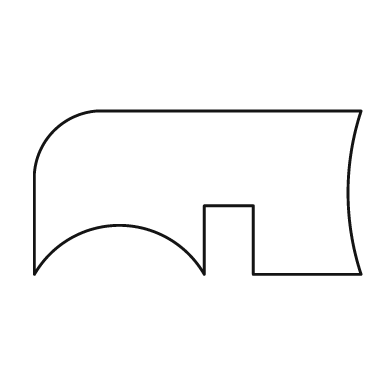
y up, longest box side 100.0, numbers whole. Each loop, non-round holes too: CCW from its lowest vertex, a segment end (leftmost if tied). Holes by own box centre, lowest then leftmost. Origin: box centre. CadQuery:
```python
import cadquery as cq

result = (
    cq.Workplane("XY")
    .moveTo(-50.0, -25.0)
    .threePointArc((-24.0, -10.0), (2.0, -25.0))
    .lineTo(2.0, -4.0)
    .lineTo(17.0, -4.0)
    .lineTo(17.0, -25.0)
    .lineTo(50.0, -25.0)
    .threePointArc((46.0, 0.0), (50.0, 25.0))
    .lineTo(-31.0, 25.0)
    .threePointArc((-44.0, 19.0), (-50.0, 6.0))
    .close()
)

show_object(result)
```